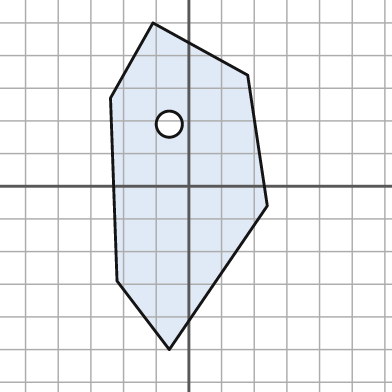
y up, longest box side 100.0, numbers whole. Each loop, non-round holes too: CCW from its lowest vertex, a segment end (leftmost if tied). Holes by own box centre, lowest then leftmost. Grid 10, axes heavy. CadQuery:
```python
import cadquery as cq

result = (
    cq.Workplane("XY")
    .moveTo(-6.0, -50.0)
    .lineTo(24.0, -6.0)
    .lineTo(18.0, 34.0)
    .lineTo(-11.0, 50.0)
    .lineTo(-24.0, 27.0)
    .lineTo(-22.0, -29.0)
    .close()
    .moveTo(-6.0, 19.0)
    .circle(4.0)
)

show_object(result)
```